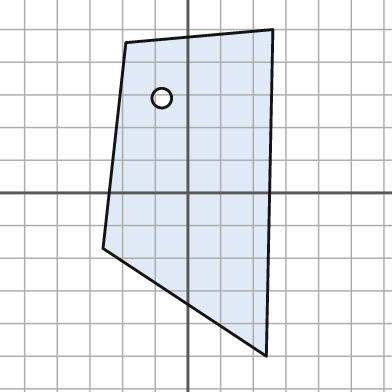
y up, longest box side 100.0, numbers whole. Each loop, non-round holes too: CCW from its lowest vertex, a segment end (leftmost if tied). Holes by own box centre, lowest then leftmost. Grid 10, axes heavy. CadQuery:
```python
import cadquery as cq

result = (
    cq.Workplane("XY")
    .moveTo(24.0, -50.0)
    .lineTo(26.0, 50.0)
    .lineTo(-19.0, 46.0)
    .lineTo(-26.0, -17.0)
    .close()
    .moveTo(-8.0, 29.0)
    .circle(3.0)
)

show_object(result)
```